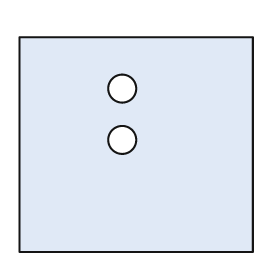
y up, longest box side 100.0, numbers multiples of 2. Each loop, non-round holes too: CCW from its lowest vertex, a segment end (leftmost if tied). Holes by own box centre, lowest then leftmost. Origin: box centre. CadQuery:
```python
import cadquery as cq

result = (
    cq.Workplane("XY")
    .moveTo(-50.0, -46.0)
    .lineTo(50.0, -46.0)
    .lineTo(50.0, 46.0)
    .lineTo(-50.0, 46.0)
    .close()
    .moveTo(-6.0, 2.0)
    .circle(6.0)
    .moveTo(-6.0, 24.0)
    .circle(6.0)
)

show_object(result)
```